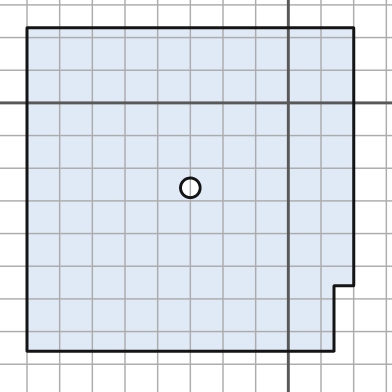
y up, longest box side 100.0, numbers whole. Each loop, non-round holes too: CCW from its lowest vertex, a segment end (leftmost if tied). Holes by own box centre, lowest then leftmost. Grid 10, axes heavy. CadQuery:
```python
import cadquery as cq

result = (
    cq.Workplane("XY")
    .moveTo(-80.0, -76.0)
    .lineTo(14.0, -76.0)
    .lineTo(14.0, -56.0)
    .lineTo(20.0, -56.0)
    .lineTo(20.0, 23.0)
    .lineTo(-80.0, 23.0)
    .close()
    .moveTo(-30.0, -26.0)
    .circle(3.0)
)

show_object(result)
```